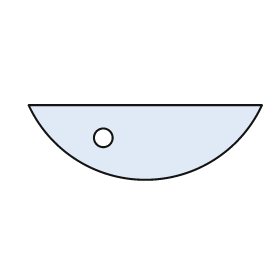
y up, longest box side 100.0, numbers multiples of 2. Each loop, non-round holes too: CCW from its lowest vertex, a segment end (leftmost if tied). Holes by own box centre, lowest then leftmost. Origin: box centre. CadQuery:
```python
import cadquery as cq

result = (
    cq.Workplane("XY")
    .moveTo(-50.0, 16.0)
    .threePointArc((0.0, -16.0), (50.0, 16.0))
    .close()
    .moveTo(-18.0, 2.0)
    .circle(4.0)
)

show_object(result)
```